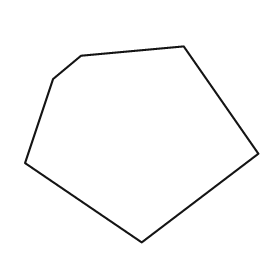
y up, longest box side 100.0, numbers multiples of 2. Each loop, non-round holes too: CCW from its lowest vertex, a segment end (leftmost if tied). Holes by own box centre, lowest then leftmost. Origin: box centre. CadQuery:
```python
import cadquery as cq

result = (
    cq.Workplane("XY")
    .moveTo(0.0, -42.0)
    .lineTo(50.0, -4.0)
    .lineTo(18.0, 42.0)
    .lineTo(-26.0, 38.0)
    .lineTo(-38.0, 28.0)
    .lineTo(-50.0, -8.0)
    .close()
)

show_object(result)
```